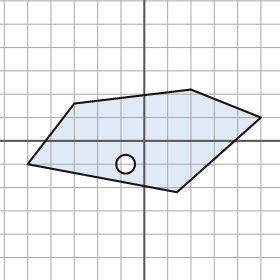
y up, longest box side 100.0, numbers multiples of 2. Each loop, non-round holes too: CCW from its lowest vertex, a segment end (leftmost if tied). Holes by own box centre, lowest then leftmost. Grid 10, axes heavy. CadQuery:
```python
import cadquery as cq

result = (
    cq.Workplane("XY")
    .moveTo(14.0, -22.0)
    .lineTo(50.0, 10.0)
    .lineTo(20.0, 22.0)
    .lineTo(-30.0, 16.0)
    .lineTo(-50.0, -10.0)
    .close()
    .moveTo(-8.0, -10.0)
    .circle(4.0)
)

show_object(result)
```